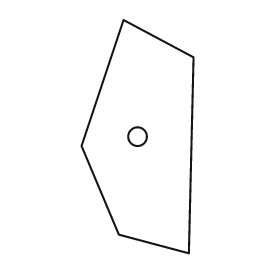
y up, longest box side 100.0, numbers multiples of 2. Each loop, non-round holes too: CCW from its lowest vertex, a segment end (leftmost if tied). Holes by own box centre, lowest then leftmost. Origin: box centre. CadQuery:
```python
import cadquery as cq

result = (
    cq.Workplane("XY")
    .moveTo(22.0, -50.0)
    .lineTo(24.0, 34.0)
    .lineTo(-6.0, 50.0)
    .lineTo(-24.0, -4.0)
    .lineTo(-8.0, -42.0)
    .close()
    .moveTo(0.0, 0.0)
    .circle(4.0)
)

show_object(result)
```